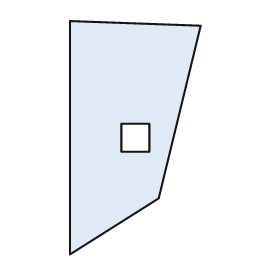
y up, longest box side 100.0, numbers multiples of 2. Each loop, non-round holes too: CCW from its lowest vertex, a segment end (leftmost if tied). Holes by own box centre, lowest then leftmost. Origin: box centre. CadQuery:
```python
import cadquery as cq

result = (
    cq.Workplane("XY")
    .moveTo(-28.0, -50.0)
    .lineTo(10.0, -26.0)
    .lineTo(28.0, 48.0)
    .lineTo(-28.0, 50.0)
    .close()
    .moveTo(-6.0, -6.0)
    .lineTo(6.0, -6.0)
    .lineTo(6.0, 6.0)
    .lineTo(-6.0, 6.0)
    .close()
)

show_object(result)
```